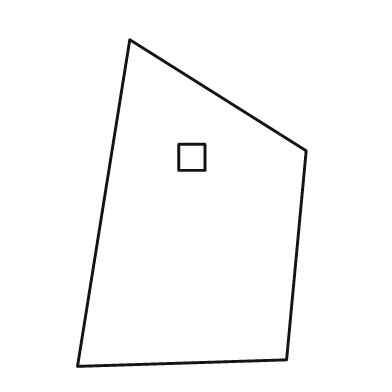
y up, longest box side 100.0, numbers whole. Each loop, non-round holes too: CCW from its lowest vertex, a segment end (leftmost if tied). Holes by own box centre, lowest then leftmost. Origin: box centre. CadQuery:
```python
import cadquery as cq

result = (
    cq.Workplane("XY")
    .moveTo(-35.0, -50.0)
    .lineTo(29.0, -48.0)
    .lineTo(35.0, 16.0)
    .lineTo(-19.0, 50.0)
    .close()
    .moveTo(-4.0, 10.0)
    .lineTo(4.0, 10.0)
    .lineTo(4.0, 18.0)
    .lineTo(-4.0, 18.0)
    .close()
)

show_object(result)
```